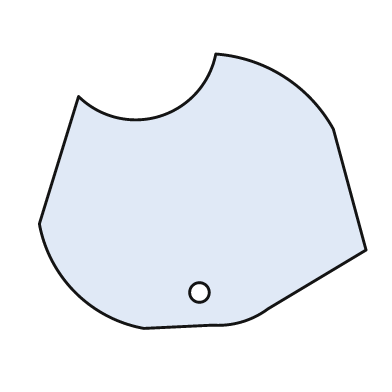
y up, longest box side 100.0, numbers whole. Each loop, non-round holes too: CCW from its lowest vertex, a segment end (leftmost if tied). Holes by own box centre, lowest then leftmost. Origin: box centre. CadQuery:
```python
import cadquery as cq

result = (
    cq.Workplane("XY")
    .moveTo(-18.0, -42.0)
    .lineTo(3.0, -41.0)
    .threePointArc((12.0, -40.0), (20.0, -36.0))
    .lineTo(50.0, -18.0)
    .lineTo(40.0, 19.0)
    .threePointArc((25.0, 35.0), (4.0, 42.0))
    .threePointArc((-13.0, 23.0), (-38.0, 29.0))
    .lineTo(-50.0, -10.0)
    .threePointArc((-39.0, -31.0), (-18.0, -42.0))
    .close()
    .moveTo(-1.0, -31.0)
    .circle(3.0)
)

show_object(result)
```